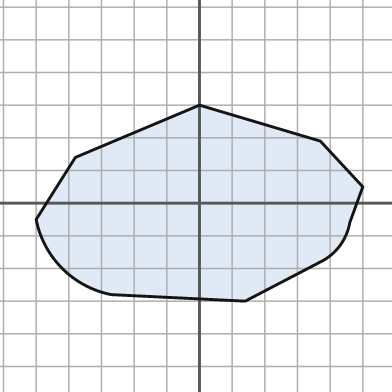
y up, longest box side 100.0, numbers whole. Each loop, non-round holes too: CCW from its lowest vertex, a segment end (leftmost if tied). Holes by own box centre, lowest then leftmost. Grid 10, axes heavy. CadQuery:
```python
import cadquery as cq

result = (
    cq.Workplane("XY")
    .moveTo(14.0, -30.0)
    .lineTo(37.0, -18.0)
    .threePointArc((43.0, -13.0), (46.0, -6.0))
    .lineTo(50.0, 5.0)
    .lineTo(37.0, 19.0)
    .lineTo(0.0, 30.0)
    .lineTo(-38.0, 14.0)
    .lineTo(-50.0, -5.0)
    .threePointArc((-42.0, -20.0), (-27.0, -28.0))
    .close()
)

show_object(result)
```